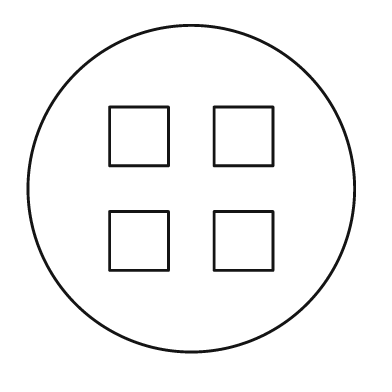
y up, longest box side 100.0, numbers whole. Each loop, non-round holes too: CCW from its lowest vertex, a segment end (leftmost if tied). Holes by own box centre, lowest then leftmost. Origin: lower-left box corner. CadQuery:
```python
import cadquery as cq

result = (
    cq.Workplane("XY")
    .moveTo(50.0, 50.0)
    .circle(50.0)
    .moveTo(25.0, 25.0)
    .lineTo(43.0, 25.0)
    .lineTo(43.0, 43.0)
    .lineTo(25.0, 43.0)
    .close()
    .moveTo(57.0, 25.0)
    .lineTo(75.0, 25.0)
    .lineTo(75.0, 43.0)
    .lineTo(57.0, 43.0)
    .close()
    .moveTo(25.0, 57.0)
    .lineTo(43.0, 57.0)
    .lineTo(43.0, 75.0)
    .lineTo(25.0, 75.0)
    .close()
    .moveTo(57.0, 57.0)
    .lineTo(75.0, 57.0)
    .lineTo(75.0, 75.0)
    .lineTo(57.0, 75.0)
    .close()
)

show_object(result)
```